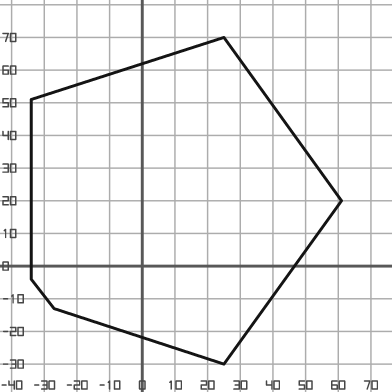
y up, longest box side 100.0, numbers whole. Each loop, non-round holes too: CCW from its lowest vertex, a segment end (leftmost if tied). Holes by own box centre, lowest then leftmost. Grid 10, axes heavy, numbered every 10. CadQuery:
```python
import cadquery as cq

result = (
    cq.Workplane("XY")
    .moveTo(25.0, -30.0)
    .lineTo(61.0, 20.0)
    .lineTo(25.0, 70.0)
    .lineTo(-34.0, 51.0)
    .lineTo(-34.0, -4.0)
    .lineTo(-27.0, -13.0)
    .close()
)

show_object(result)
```